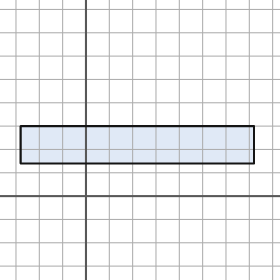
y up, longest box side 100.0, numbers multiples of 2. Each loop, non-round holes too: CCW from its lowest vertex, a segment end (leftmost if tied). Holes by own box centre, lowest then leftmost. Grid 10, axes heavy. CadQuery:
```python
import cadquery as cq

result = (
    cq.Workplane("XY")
    .moveTo(-28.0, 14.0)
    .lineTo(72.0, 14.0)
    .lineTo(72.0, 30.0)
    .lineTo(-28.0, 30.0)
    .close()
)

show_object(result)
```